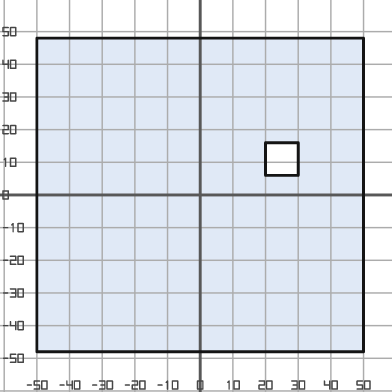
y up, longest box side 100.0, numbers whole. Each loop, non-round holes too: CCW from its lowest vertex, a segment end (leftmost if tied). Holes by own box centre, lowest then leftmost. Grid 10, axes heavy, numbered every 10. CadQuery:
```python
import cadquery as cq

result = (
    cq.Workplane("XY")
    .moveTo(-50.0, -48.0)
    .lineTo(50.0, -48.0)
    .lineTo(50.0, 48.0)
    .lineTo(-50.0, 48.0)
    .close()
    .moveTo(20.0, 6.0)
    .lineTo(30.0, 6.0)
    .lineTo(30.0, 16.0)
    .lineTo(20.0, 16.0)
    .close()
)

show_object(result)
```